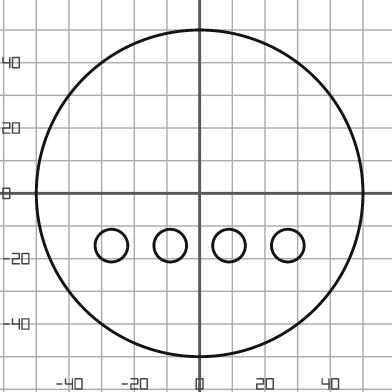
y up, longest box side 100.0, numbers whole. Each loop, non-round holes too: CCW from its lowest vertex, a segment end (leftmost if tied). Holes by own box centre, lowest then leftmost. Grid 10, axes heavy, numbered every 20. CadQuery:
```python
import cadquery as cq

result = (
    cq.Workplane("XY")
    .moveTo(0.0, 0.0)
    .circle(50.0)
    .moveTo(-27.0, -16.0)
    .circle(5.0)
    .moveTo(-9.0, -16.0)
    .circle(5.0)
    .moveTo(9.0, -16.0)
    .circle(5.0)
    .moveTo(27.0, -16.0)
    .circle(5.0)
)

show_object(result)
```